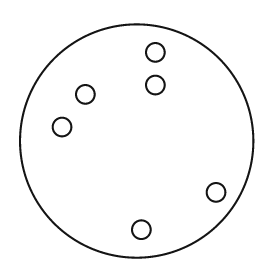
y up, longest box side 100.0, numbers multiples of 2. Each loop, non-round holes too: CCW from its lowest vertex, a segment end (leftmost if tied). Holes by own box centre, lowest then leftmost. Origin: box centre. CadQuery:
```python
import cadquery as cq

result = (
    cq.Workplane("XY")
    .moveTo(0.0, 0.0)
    .circle(50.0)
    .moveTo(2.0, -38.0)
    .circle(4.0)
    .moveTo(34.0, -22.0)
    .circle(4.0)
    .moveTo(-32.0, 6.0)
    .circle(4.0)
    .moveTo(-22.0, 20.0)
    .circle(4.0)
    .moveTo(8.0, 24.0)
    .circle(4.0)
    .moveTo(8.0, 38.0)
    .circle(4.0)
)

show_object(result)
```